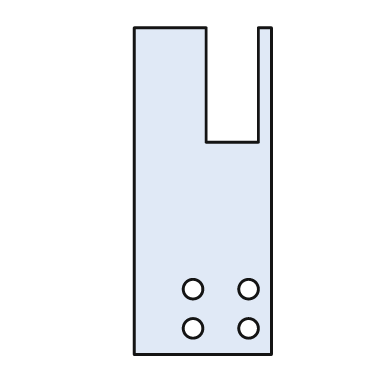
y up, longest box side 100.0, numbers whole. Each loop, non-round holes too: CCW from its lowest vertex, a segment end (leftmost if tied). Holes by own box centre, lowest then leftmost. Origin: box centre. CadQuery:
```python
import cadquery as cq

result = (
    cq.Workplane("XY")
    .moveTo(-21.0, -50.0)
    .lineTo(21.0, -50.0)
    .lineTo(21.0, 50.0)
    .lineTo(17.0, 50.0)
    .lineTo(17.0, 15.0)
    .lineTo(1.0, 15.0)
    .lineTo(1.0, 50.0)
    .lineTo(-21.0, 50.0)
    .close()
    .moveTo(-3.0, -42.0)
    .circle(3.0)
    .moveTo(14.0, -42.0)
    .circle(3.0)
    .moveTo(-3.0, -30.0)
    .circle(3.0)
    .moveTo(14.0, -30.0)
    .circle(3.0)
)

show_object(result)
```